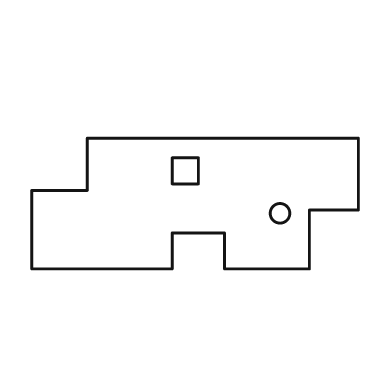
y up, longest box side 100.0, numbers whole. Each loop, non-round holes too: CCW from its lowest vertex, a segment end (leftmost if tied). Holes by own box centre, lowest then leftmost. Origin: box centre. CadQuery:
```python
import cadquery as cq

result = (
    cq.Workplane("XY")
    .moveTo(-50.0, -20.0)
    .lineTo(-7.0, -20.0)
    .lineTo(-7.0, -9.0)
    .lineTo(9.0, -9.0)
    .lineTo(9.0, -20.0)
    .lineTo(35.0, -20.0)
    .lineTo(35.0, -2.0)
    .lineTo(50.0, -2.0)
    .lineTo(50.0, 20.0)
    .lineTo(-33.0, 20.0)
    .lineTo(-33.0, 4.0)
    .lineTo(-50.0, 4.0)
    .close()
    .moveTo(26.0, -3.0)
    .circle(3.0)
    .moveTo(-7.0, 6.0)
    .lineTo(1.0, 6.0)
    .lineTo(1.0, 14.0)
    .lineTo(-7.0, 14.0)
    .close()
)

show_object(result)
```